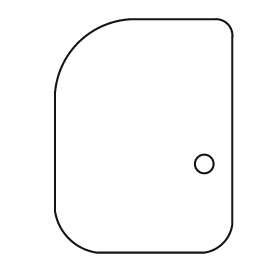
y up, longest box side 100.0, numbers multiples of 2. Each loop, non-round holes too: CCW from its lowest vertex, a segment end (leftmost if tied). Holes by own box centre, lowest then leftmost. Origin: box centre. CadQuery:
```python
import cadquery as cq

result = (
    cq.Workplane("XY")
    .moveTo(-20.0, -50.0)
    .lineTo(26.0, -50.0)
    .threePointArc((34.0, -46.0), (38.0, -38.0))
    .lineTo(38.0, 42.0)
    .threePointArc((36.0, 48.0), (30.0, 50.0))
    .lineTo(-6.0, 50.0)
    .threePointArc((-28.0, 40.0), (-38.0, 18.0))
    .lineTo(-38.0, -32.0)
    .threePointArc((-32.0, -44.0), (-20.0, -50.0))
    .close()
    .moveTo(26.0, -12.0)
    .circle(4.0)
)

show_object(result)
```